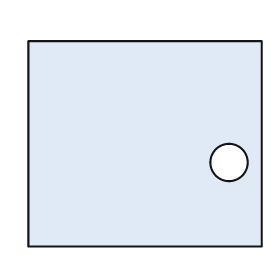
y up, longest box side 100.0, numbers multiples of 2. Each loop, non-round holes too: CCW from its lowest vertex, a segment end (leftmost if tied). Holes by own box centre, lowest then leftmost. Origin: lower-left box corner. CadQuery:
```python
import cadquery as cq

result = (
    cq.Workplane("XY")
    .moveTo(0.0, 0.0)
    .lineTo(100.0, 0.0)
    .lineTo(100.0, 88.0)
    .lineTo(0.0, 88.0)
    .close()
    .moveTo(86.0, 36.0)
    .circle(8.0)
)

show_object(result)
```